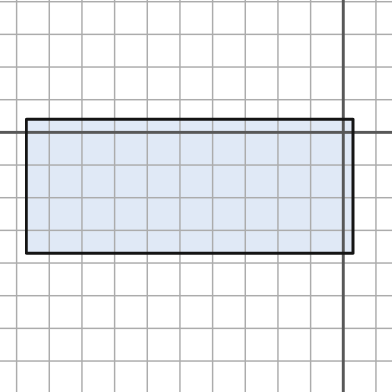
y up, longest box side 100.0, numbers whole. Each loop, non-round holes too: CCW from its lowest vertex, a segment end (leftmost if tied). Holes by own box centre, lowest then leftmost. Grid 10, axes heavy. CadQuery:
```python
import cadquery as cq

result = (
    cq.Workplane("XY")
    .moveTo(-97.0, -37.0)
    .lineTo(3.0, -37.0)
    .lineTo(3.0, 4.0)
    .lineTo(-97.0, 4.0)
    .close()
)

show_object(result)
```